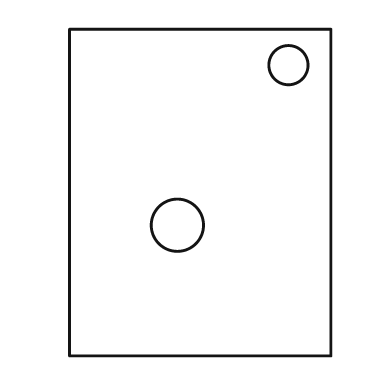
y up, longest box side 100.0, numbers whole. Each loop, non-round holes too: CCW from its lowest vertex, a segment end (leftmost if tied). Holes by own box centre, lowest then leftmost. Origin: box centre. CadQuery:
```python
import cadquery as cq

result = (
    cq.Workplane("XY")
    .moveTo(-40.0, -50.0)
    .lineTo(40.0, -50.0)
    .lineTo(40.0, 50.0)
    .lineTo(-40.0, 50.0)
    .close()
    .moveTo(-7.0, -10.0)
    .circle(8.0)
    .moveTo(27.0, 39.0)
    .circle(6.0)
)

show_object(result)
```